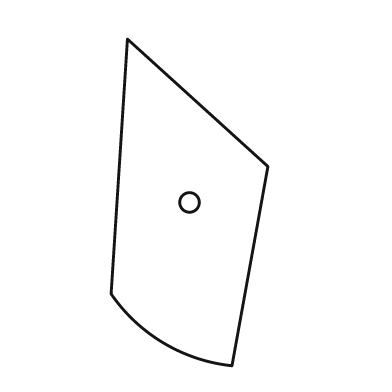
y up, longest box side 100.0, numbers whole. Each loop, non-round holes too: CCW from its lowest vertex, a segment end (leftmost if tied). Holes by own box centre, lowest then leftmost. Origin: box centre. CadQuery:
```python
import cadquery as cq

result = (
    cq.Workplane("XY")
    .moveTo(13.0, -50.0)
    .lineTo(24.0, 11.0)
    .lineTo(-19.0, 50.0)
    .lineTo(-24.0, -28.0)
    .threePointArc((-8.0, -43.0), (13.0, -50.0))
    .close()
    .moveTo(0.0, 0.0)
    .circle(3.0)
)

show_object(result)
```